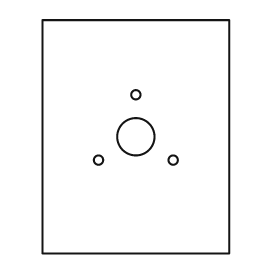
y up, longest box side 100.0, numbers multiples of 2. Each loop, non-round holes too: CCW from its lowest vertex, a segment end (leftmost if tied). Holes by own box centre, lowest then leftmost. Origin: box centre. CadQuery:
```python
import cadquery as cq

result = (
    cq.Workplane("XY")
    .moveTo(-40.0, -50.0)
    .lineTo(40.0, -50.0)
    .lineTo(40.0, 50.0)
    .lineTo(-40.0, 50.0)
    .close()
    .moveTo(-16.0, -10.0)
    .circle(2.0)
    .moveTo(16.0, -10.0)
    .circle(2.0)
    .moveTo(0.0, 0.0)
    .circle(8.0)
    .moveTo(0.0, 18.0)
    .circle(2.0)
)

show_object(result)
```